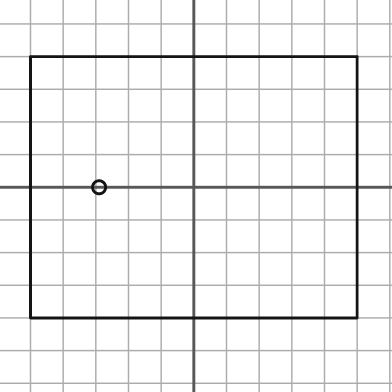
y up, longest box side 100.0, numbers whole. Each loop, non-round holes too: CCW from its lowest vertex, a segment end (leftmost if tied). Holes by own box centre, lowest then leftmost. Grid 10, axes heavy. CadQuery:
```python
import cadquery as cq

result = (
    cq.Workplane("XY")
    .moveTo(-50.0, -40.0)
    .lineTo(50.0, -40.0)
    .lineTo(50.0, 40.0)
    .lineTo(-50.0, 40.0)
    .close()
    .moveTo(-29.0, 0.0)
    .circle(2.0)
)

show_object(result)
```